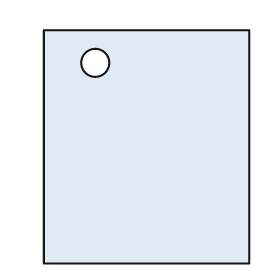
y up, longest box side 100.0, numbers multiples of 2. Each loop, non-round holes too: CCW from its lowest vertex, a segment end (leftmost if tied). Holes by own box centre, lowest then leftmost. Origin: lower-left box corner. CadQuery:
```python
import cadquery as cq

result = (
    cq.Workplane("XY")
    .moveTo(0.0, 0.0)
    .lineTo(88.0, 0.0)
    .lineTo(88.0, 100.0)
    .lineTo(0.0, 100.0)
    .close()
    .moveTo(22.0, 86.0)
    .circle(6.0)
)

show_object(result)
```